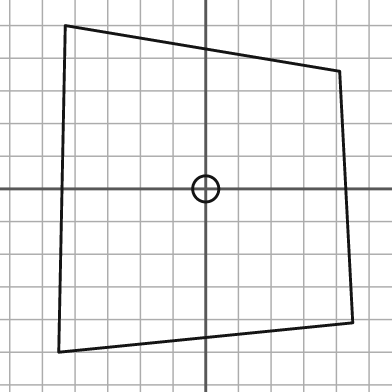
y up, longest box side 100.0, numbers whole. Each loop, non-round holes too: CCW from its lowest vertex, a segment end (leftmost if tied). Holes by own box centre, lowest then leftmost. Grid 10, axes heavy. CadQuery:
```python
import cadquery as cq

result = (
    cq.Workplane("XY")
    .moveTo(-45.0, -50.0)
    .lineTo(45.0, -41.0)
    .lineTo(41.0, 36.0)
    .lineTo(-43.0, 50.0)
    .close()
    .moveTo(0.0, 0.0)
    .circle(4.0)
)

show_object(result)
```